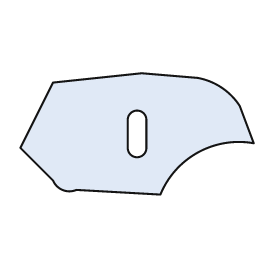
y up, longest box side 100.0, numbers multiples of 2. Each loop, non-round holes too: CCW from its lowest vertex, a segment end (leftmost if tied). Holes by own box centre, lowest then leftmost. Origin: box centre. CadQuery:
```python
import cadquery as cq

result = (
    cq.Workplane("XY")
    .moveTo(10.0, -26.0)
    .threePointArc((26.0, -8.0), (50.0, -4.0))
    .lineTo(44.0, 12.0)
    .threePointArc((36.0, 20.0), (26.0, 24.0))
    .lineTo(2.0, 26.0)
    .lineTo(-36.0, 22.0)
    .lineTo(-50.0, -6.0)
    .lineTo(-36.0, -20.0)
    .threePointArc((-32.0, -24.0), (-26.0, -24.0))
    .close()
    .moveTo(-4.0, -6.0)
    .threePointArc((0.0, -10.0), (4.0, -6.0))
    .lineTo(4.0, 6.0)
    .threePointArc((0.0, 10.0), (-4.0, 6.0))
    .close()
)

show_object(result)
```